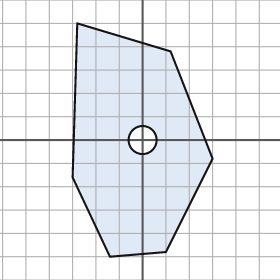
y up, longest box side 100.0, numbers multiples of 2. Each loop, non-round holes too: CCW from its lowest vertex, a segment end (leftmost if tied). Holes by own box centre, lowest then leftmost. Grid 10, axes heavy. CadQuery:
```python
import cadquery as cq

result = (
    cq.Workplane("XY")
    .moveTo(-14.0, -50.0)
    .lineTo(10.0, -48.0)
    .lineTo(30.0, -8.0)
    .lineTo(12.0, 38.0)
    .lineTo(-28.0, 50.0)
    .lineTo(-30.0, -16.0)
    .close()
    .moveTo(0.0, 0.0)
    .circle(6.0)
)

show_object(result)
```